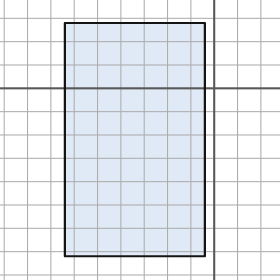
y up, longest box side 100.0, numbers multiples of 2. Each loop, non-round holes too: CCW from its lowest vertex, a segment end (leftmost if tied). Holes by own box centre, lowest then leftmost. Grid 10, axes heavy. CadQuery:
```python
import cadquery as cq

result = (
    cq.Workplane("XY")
    .moveTo(-64.0, -72.0)
    .lineTo(-4.0, -72.0)
    .lineTo(-4.0, 28.0)
    .lineTo(-64.0, 28.0)
    .close()
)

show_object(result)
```